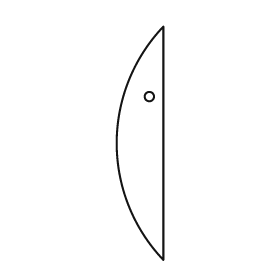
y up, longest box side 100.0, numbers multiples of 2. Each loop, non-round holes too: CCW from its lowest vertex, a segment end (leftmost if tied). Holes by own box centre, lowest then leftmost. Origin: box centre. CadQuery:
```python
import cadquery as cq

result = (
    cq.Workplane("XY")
    .moveTo(10.0, -50.0)
    .lineTo(10.0, 50.0)
    .threePointArc((-10.0, 0.0), (10.0, -50.0))
    .close()
    .moveTo(4.0, 20.0)
    .circle(2.0)
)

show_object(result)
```